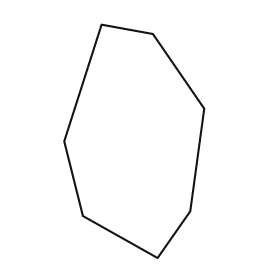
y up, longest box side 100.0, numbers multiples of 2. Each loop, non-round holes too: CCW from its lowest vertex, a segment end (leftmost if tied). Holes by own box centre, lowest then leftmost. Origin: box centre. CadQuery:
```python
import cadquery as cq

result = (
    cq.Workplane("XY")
    .moveTo(10.0, -50.0)
    .lineTo(24.0, -30.0)
    .lineTo(30.0, 14.0)
    .lineTo(8.0, 46.0)
    .lineTo(-14.0, 50.0)
    .lineTo(-30.0, 0.0)
    .lineTo(-22.0, -32.0)
    .close()
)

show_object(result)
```